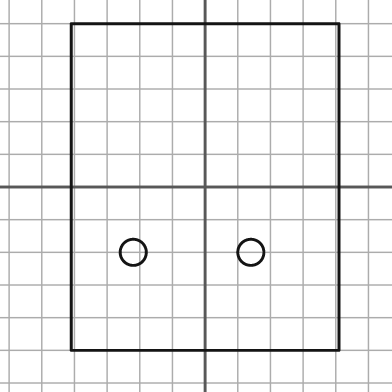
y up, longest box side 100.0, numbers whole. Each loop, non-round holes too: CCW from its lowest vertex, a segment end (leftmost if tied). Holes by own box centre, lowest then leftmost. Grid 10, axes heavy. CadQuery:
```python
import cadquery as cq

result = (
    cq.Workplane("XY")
    .moveTo(-41.0, -50.0)
    .lineTo(41.0, -50.0)
    .lineTo(41.0, 50.0)
    .lineTo(-41.0, 50.0)
    .close()
    .moveTo(-22.0, -20.0)
    .circle(4.0)
    .moveTo(14.0, -20.0)
    .circle(4.0)
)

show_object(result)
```